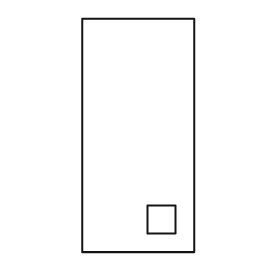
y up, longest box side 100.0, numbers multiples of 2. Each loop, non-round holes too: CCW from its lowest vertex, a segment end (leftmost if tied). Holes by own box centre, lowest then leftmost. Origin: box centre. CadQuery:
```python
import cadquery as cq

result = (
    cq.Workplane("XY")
    .moveTo(-24.0, -50.0)
    .lineTo(24.0, -50.0)
    .lineTo(24.0, 50.0)
    .lineTo(-24.0, 50.0)
    .close()
    .moveTo(4.0, -42.0)
    .lineTo(16.0, -42.0)
    .lineTo(16.0, -30.0)
    .lineTo(4.0, -30.0)
    .close()
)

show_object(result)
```